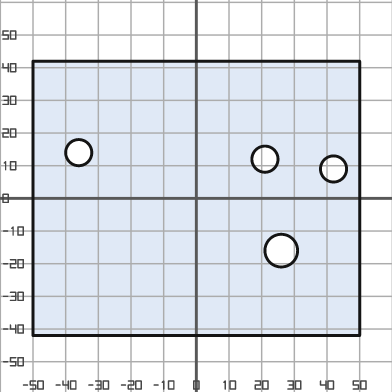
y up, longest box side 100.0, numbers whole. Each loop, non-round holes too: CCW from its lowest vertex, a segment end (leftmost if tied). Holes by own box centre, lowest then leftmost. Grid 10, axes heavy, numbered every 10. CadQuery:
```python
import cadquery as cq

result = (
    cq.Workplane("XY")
    .moveTo(-50.0, -42.0)
    .lineTo(50.0, -42.0)
    .lineTo(50.0, 42.0)
    .lineTo(-50.0, 42.0)
    .close()
    .moveTo(26.0, -16.0)
    .circle(5.0)
    .moveTo(42.0, 9.0)
    .circle(4.0)
    .moveTo(21.0, 12.0)
    .circle(4.0)
    .moveTo(-36.0, 14.0)
    .circle(4.0)
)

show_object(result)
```